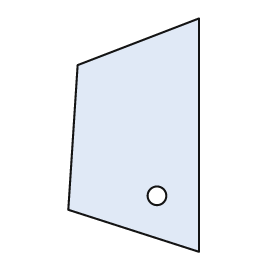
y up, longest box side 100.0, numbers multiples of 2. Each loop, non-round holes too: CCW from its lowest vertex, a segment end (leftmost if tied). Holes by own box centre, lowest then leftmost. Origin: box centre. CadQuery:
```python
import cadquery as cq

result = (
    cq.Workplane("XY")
    .moveTo(28.0, -50.0)
    .lineTo(28.0, 50.0)
    .lineTo(-24.0, 30.0)
    .lineTo(-28.0, -32.0)
    .close()
    .moveTo(10.0, -26.0)
    .circle(4.0)
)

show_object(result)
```